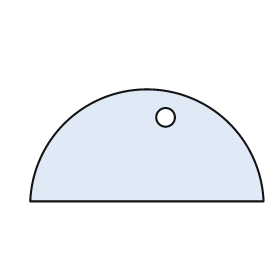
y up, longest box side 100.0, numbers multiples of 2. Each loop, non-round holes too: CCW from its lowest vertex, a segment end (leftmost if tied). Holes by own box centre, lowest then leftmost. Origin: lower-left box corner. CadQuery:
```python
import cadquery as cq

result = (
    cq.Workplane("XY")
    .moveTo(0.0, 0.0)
    .lineTo(100.0, 0.0)
    .threePointArc((50.0, 48.0), (0.0, 0.0))
    .close()
    .moveTo(58.0, 36.0)
    .circle(4.0)
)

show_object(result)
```